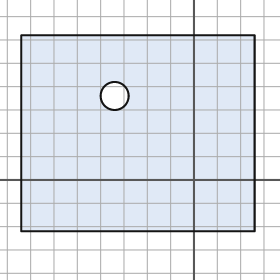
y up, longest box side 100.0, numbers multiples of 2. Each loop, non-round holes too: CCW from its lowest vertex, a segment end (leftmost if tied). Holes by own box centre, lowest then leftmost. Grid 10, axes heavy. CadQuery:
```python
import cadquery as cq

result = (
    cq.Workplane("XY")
    .moveTo(-74.0, -22.0)
    .lineTo(26.0, -22.0)
    .lineTo(26.0, 62.0)
    .lineTo(-74.0, 62.0)
    .close()
    .moveTo(-34.0, 36.0)
    .circle(6.0)
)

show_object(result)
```